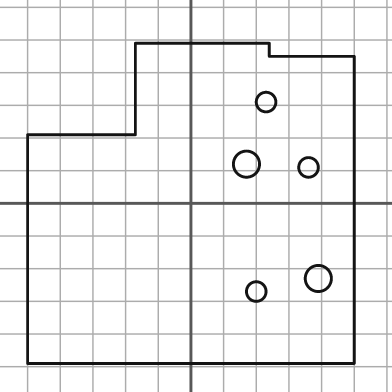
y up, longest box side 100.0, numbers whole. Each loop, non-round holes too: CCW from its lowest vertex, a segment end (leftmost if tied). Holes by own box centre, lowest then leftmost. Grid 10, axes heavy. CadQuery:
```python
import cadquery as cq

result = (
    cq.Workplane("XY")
    .moveTo(-50.0, -49.0)
    .lineTo(50.0, -49.0)
    .lineTo(50.0, 45.0)
    .lineTo(24.0, 45.0)
    .lineTo(24.0, 49.0)
    .lineTo(-17.0, 49.0)
    .lineTo(-17.0, 21.0)
    .lineTo(-50.0, 21.0)
    .close()
    .moveTo(20.0, -27.0)
    .circle(3.0)
    .moveTo(39.0, -23.0)
    .circle(4.0)
    .moveTo(36.0, 11.0)
    .circle(3.0)
    .moveTo(17.0, 12.0)
    .circle(4.0)
    .moveTo(23.0, 31.0)
    .circle(3.0)
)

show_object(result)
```